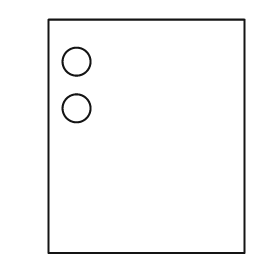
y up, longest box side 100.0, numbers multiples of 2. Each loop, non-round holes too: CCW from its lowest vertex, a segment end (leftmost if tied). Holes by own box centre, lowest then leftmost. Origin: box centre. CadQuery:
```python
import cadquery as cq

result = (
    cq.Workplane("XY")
    .moveTo(-42.0, -50.0)
    .lineTo(42.0, -50.0)
    .lineTo(42.0, 50.0)
    .lineTo(-42.0, 50.0)
    .close()
    .moveTo(-30.0, 12.0)
    .circle(6.0)
    .moveTo(-30.0, 32.0)
    .circle(6.0)
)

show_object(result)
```